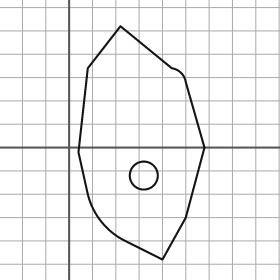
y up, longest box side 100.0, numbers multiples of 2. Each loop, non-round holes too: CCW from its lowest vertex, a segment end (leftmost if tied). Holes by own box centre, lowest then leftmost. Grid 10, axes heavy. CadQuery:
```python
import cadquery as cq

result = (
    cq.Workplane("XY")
    .moveTo(40.0, -48.0)
    .lineTo(50.0, -30.0)
    .lineTo(58.0, 0.0)
    .lineTo(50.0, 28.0)
    .threePointArc((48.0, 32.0), (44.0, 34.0))
    .lineTo(22.0, 52.0)
    .lineTo(8.0, 34.0)
    .lineTo(4.0, -2.0)
    .lineTo(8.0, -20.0)
    .threePointArc((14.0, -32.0), (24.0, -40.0))
    .close()
    .moveTo(32.0, -12.0)
    .circle(6.0)
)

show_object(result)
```